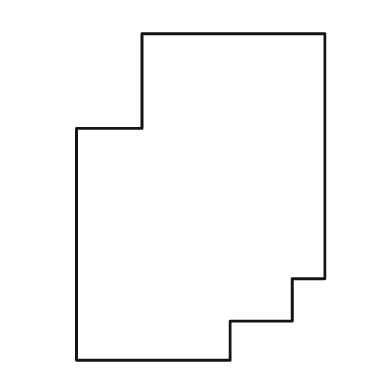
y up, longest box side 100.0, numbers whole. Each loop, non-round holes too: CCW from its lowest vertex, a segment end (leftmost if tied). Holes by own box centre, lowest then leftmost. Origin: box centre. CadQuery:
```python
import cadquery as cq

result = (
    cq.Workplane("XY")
    .moveTo(-38.0, -50.0)
    .lineTo(9.0, -50.0)
    .lineTo(9.0, -38.0)
    .lineTo(28.0, -38.0)
    .lineTo(28.0, -25.0)
    .lineTo(38.0, -25.0)
    .lineTo(38.0, 50.0)
    .lineTo(-18.0, 50.0)
    .lineTo(-18.0, 21.0)
    .lineTo(-38.0, 21.0)
    .close()
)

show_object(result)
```